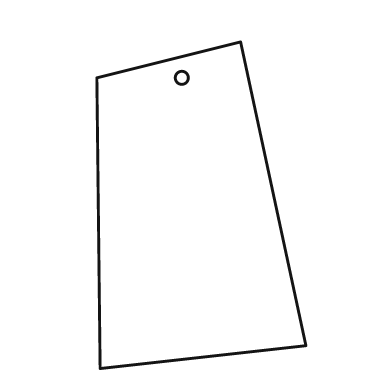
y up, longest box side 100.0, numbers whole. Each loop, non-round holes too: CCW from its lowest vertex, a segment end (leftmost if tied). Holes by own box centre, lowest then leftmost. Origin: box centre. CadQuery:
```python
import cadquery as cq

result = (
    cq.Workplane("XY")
    .moveTo(-31.0, -50.0)
    .lineTo(32.0, -43.0)
    .lineTo(12.0, 50.0)
    .lineTo(-32.0, 39.0)
    .close()
    .moveTo(-6.0, 39.0)
    .circle(2.0)
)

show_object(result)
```